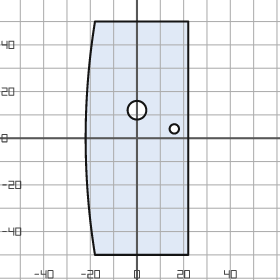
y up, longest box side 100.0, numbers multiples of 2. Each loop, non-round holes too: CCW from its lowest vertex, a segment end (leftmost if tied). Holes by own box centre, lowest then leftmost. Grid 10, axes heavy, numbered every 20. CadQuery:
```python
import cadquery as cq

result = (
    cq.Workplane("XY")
    .moveTo(-18.0, -50.0)
    .lineTo(22.0, -50.0)
    .lineTo(22.0, 50.0)
    .lineTo(-18.0, 50.0)
    .threePointArc((-22.0, 0.0), (-18.0, -50.0))
    .close()
    .moveTo(16.0, 4.0)
    .circle(2.0)
    .moveTo(0.0, 12.0)
    .circle(4.0)
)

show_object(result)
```